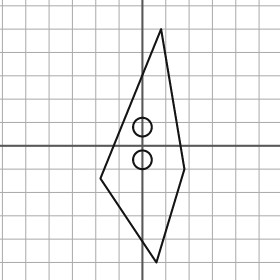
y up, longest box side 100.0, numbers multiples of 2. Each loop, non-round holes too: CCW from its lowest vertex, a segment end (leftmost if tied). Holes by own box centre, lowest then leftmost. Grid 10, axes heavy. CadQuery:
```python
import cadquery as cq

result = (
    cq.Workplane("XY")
    .moveTo(6.0, -50.0)
    .lineTo(18.0, -10.0)
    .lineTo(8.0, 50.0)
    .lineTo(-18.0, -14.0)
    .close()
    .moveTo(0.0, -6.0)
    .circle(4.0)
    .moveTo(0.0, 8.0)
    .circle(4.0)
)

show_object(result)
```